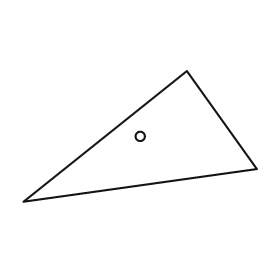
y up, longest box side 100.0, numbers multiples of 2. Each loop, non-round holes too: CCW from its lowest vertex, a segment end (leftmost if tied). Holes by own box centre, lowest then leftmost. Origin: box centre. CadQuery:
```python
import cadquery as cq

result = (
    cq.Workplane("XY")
    .moveTo(-50.0, -28.0)
    .lineTo(50.0, -14.0)
    .lineTo(20.0, 28.0)
    .close()
    .moveTo(0.0, 0.0)
    .circle(2.0)
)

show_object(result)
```